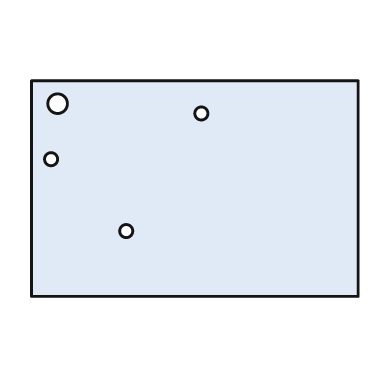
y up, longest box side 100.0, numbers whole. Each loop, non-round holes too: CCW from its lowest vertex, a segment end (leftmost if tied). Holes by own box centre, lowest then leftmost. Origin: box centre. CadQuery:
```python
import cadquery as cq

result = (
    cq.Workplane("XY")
    .moveTo(-50.0, -33.0)
    .lineTo(50.0, -33.0)
    .lineTo(50.0, 33.0)
    .lineTo(-50.0, 33.0)
    .close()
    .moveTo(-21.0, -13.0)
    .circle(2.0)
    .moveTo(-44.0, 9.0)
    .circle(2.0)
    .moveTo(2.0, 23.0)
    .circle(2.0)
    .moveTo(-42.0, 26.0)
    .circle(3.0)
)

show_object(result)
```